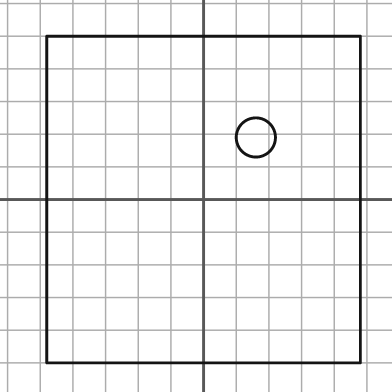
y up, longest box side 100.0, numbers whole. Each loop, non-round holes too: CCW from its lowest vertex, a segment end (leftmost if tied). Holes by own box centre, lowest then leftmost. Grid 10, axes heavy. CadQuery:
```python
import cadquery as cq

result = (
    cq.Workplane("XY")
    .moveTo(-48.0, -50.0)
    .lineTo(48.0, -50.0)
    .lineTo(48.0, 50.0)
    .lineTo(-48.0, 50.0)
    .close()
    .moveTo(16.0, 19.0)
    .circle(6.0)
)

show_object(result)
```